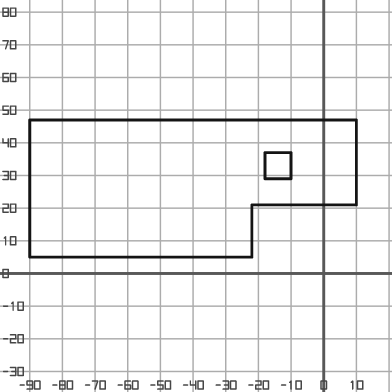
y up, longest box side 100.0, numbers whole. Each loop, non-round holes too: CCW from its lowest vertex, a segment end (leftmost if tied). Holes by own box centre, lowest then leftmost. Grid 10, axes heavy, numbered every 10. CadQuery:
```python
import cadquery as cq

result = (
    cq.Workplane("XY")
    .moveTo(-90.0, 5.0)
    .lineTo(-22.0, 5.0)
    .lineTo(-22.0, 21.0)
    .lineTo(10.0, 21.0)
    .lineTo(10.0, 47.0)
    .lineTo(-90.0, 47.0)
    .close()
    .moveTo(-18.0, 29.0)
    .lineTo(-10.0, 29.0)
    .lineTo(-10.0, 37.0)
    .lineTo(-18.0, 37.0)
    .close()
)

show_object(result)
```